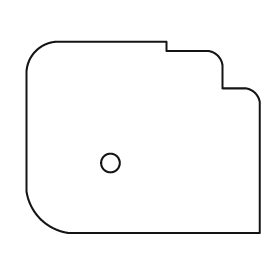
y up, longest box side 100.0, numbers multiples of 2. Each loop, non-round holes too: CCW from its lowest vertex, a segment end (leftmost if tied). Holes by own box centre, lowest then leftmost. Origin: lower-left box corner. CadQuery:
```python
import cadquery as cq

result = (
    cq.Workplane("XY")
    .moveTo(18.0, 0.0)
    .lineTo(100.0, 0.0)
    .lineTo(100.0, 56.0)
    .threePointArc((98.0, 60.0), (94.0, 62.0))
    .lineTo(84.0, 62.0)
    .lineTo(84.0, 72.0)
    .threePointArc((82.0, 76.0), (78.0, 78.0))
    .lineTo(60.0, 78.0)
    .lineTo(60.0, 82.0)
    .lineTo(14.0, 82.0)
    .threePointArc((4.0, 78.0), (0.0, 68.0))
    .lineTo(0.0, 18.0)
    .threePointArc((6.0, 6.0), (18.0, 0.0))
    .close()
    .moveTo(36.0, 30.0)
    .circle(4.0)
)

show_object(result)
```